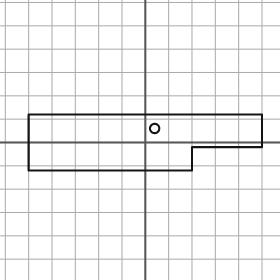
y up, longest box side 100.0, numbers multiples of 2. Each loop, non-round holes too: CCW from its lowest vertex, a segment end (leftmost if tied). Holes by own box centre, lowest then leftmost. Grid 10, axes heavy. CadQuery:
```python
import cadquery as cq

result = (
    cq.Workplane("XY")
    .moveTo(-50.0, -12.0)
    .lineTo(20.0, -12.0)
    .lineTo(20.0, -2.0)
    .lineTo(50.0, -2.0)
    .lineTo(50.0, 12.0)
    .lineTo(-50.0, 12.0)
    .close()
    .moveTo(4.0, 6.0)
    .circle(2.0)
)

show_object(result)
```